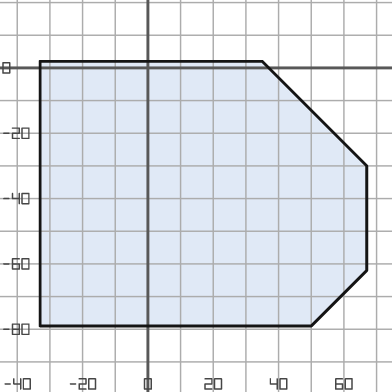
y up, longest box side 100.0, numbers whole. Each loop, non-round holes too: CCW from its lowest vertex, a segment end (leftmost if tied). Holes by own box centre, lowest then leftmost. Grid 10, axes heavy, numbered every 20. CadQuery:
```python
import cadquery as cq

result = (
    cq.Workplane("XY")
    .moveTo(-33.0, -79.0)
    .lineTo(50.0, -79.0)
    .lineTo(67.0, -62.0)
    .lineTo(67.0, -30.0)
    .lineTo(35.0, 2.0)
    .lineTo(-33.0, 2.0)
    .close()
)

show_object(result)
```